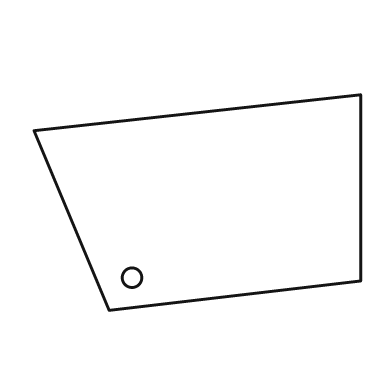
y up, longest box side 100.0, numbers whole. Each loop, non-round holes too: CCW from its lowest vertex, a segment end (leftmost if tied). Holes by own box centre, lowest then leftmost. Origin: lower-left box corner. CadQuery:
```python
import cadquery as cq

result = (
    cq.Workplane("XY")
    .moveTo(23.0, 0.0)
    .lineTo(100.0, 9.0)
    .lineTo(100.0, 66.0)
    .lineTo(0.0, 55.0)
    .close()
    .moveTo(30.0, 10.0)
    .circle(3.0)
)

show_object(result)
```